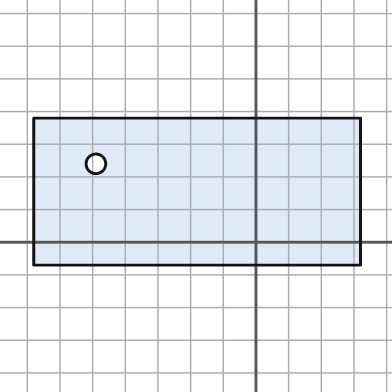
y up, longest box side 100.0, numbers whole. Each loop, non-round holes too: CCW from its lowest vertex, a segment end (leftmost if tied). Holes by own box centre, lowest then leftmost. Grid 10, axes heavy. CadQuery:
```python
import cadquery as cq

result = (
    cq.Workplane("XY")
    .moveTo(-68.0, -7.0)
    .lineTo(32.0, -7.0)
    .lineTo(32.0, 38.0)
    .lineTo(-68.0, 38.0)
    .close()
    .moveTo(-49.0, 24.0)
    .circle(3.0)
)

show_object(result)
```